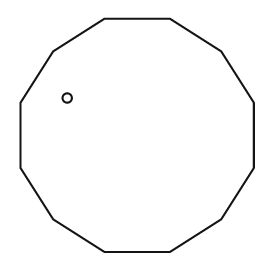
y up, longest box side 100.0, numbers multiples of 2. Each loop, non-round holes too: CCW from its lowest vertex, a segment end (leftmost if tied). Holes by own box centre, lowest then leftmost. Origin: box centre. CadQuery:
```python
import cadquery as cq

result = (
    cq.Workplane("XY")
    .moveTo(-14.0, -50.0)
    .lineTo(14.0, -50.0)
    .lineTo(36.0, -36.0)
    .lineTo(50.0, -14.0)
    .lineTo(50.0, 14.0)
    .lineTo(36.0, 36.0)
    .lineTo(14.0, 50.0)
    .lineTo(-14.0, 50.0)
    .lineTo(-36.0, 36.0)
    .lineTo(-50.0, 14.0)
    .lineTo(-50.0, -14.0)
    .lineTo(-36.0, -36.0)
    .close()
    .moveTo(-30.0, 16.0)
    .circle(2.0)
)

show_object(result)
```